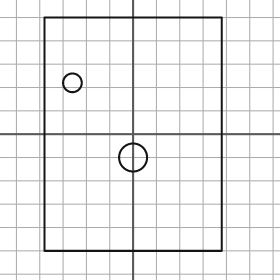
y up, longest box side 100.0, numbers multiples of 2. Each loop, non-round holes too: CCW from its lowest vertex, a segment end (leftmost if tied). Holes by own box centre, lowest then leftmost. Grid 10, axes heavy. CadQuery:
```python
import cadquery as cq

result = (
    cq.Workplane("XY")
    .moveTo(-38.0, -50.0)
    .lineTo(38.0, -50.0)
    .lineTo(38.0, 50.0)
    .lineTo(-38.0, 50.0)
    .close()
    .moveTo(0.0, -10.0)
    .circle(6.0)
    .moveTo(-26.0, 22.0)
    .circle(4.0)
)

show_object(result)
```